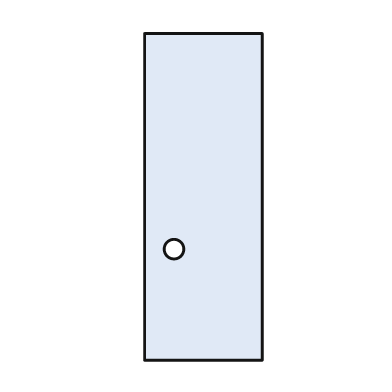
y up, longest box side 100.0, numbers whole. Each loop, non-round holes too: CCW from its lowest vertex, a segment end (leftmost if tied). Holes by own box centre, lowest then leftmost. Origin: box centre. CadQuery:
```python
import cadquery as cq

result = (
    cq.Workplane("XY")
    .moveTo(-18.0, -50.0)
    .lineTo(18.0, -50.0)
    .lineTo(18.0, 50.0)
    .lineTo(-18.0, 50.0)
    .close()
    .moveTo(-9.0, -16.0)
    .circle(3.0)
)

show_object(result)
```